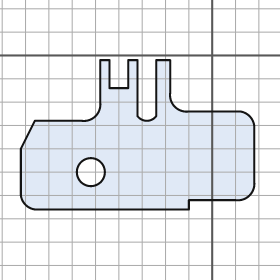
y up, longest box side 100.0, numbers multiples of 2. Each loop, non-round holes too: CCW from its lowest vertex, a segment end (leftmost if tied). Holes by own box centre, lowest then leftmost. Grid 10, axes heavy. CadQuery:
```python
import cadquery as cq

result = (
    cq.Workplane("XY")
    .moveTo(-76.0, -66.0)
    .lineTo(-10.0, -66.0)
    .lineTo(-10.0, -62.0)
    .lineTo(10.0, -62.0)
    .threePointArc((16.0, -60.0), (18.0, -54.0))
    .lineTo(18.0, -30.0)
    .threePointArc((16.0, -26.0), (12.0, -24.0))
    .lineTo(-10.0, -24.0)
    .threePointArc((-16.0, -22.0), (-18.0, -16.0))
    .lineTo(-18.0, -2.0)
    .lineTo(-24.0, -2.0)
    .lineTo(-24.0, -26.0)
    .threePointArc((-28.0, -28.0), (-32.0, -26.0))
    .lineTo(-32.0, -2.0)
    .lineTo(-36.0, -2.0)
    .lineTo(-36.0, -14.0)
    .lineTo(-44.0, -14.0)
    .lineTo(-44.0, -2.0)
    .lineTo(-48.0, -2.0)
    .lineTo(-48.0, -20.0)
    .threePointArc((-50.0, -26.0), (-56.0, -28.0))
    .lineTo(-76.0, -28.0)
    .lineTo(-82.0, -40.0)
    .lineTo(-82.0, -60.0)
    .threePointArc((-80.0, -64.0), (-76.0, -66.0))
    .close()
    .moveTo(-52.0, -50.0)
    .circle(6.0)
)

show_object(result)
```